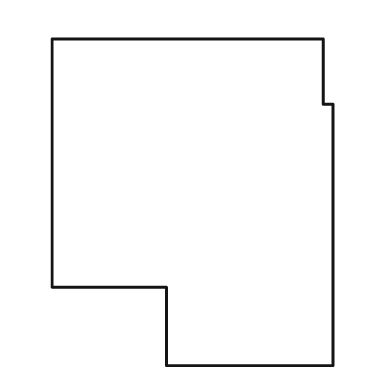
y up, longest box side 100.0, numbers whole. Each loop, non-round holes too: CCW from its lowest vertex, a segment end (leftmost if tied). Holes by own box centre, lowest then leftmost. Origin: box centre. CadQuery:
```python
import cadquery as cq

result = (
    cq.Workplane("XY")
    .moveTo(-8.0, -50.0)
    .lineTo(43.0, -50.0)
    .lineTo(43.0, 30.0)
    .lineTo(40.0, 30.0)
    .lineTo(40.0, 50.0)
    .lineTo(-43.0, 50.0)
    .lineTo(-43.0, -26.0)
    .lineTo(-8.0, -26.0)
    .close()
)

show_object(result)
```